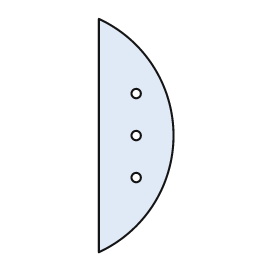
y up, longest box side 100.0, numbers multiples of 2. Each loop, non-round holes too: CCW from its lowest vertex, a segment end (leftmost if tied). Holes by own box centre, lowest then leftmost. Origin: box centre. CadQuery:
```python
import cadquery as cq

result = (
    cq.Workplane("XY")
    .moveTo(-16.0, -50.0)
    .threePointArc((16.0, 0.0), (-16.0, 50.0))
    .close()
    .moveTo(0.0, -18.0)
    .circle(2.0)
    .moveTo(0.0, 0.0)
    .circle(2.0)
    .moveTo(0.0, 18.0)
    .circle(2.0)
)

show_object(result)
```